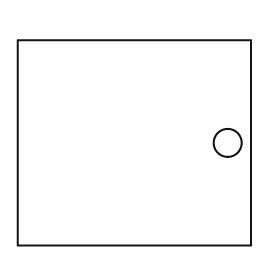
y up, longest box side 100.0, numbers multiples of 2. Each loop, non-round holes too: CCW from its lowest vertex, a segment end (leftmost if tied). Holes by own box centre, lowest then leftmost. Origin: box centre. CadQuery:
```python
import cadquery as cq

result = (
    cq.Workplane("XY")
    .moveTo(-50.0, -44.0)
    .lineTo(50.0, -44.0)
    .lineTo(50.0, 44.0)
    .lineTo(-50.0, 44.0)
    .close()
    .moveTo(40.0, 0.0)
    .circle(6.0)
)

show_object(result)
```